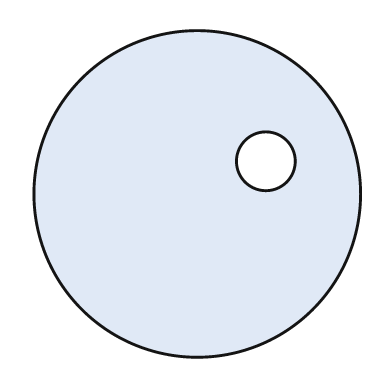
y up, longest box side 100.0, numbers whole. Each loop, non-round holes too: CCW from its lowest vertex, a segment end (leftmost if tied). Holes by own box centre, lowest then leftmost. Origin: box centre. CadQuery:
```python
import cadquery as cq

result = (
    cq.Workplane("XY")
    .moveTo(0.0, 0.0)
    .circle(50.0)
    .moveTo(21.0, 10.0)
    .circle(9.0)
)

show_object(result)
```